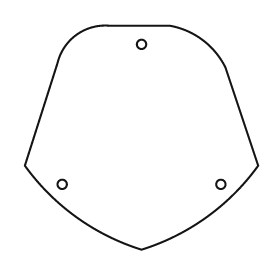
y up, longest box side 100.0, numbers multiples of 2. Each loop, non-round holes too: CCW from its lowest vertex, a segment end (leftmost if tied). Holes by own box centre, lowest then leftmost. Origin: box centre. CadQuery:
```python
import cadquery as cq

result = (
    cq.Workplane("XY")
    .moveTo(0.0, -48.0)
    .threePointArc((28.0, -34.0), (50.0, -12.0))
    .lineTo(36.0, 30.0)
    .threePointArc((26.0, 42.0), (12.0, 48.0))
    .lineTo(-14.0, 48.0)
    .threePointArc((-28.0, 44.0), (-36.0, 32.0))
    .lineTo(-50.0, -12.0)
    .threePointArc((-28.0, -34.0), (0.0, -48.0))
    .close()
    .moveTo(-34.0, -20.0)
    .circle(2.0)
    .moveTo(34.0, -20.0)
    .circle(2.0)
    .moveTo(0.0, 40.0)
    .circle(2.0)
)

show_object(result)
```